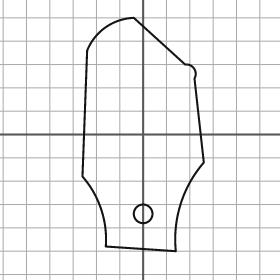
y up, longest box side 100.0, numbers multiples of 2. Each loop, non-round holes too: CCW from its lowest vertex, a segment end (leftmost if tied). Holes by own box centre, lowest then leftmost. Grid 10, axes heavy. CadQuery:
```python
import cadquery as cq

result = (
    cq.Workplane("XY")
    .moveTo(14.0, -50.0)
    .threePointArc((16.0, -30.0), (26.0, -12.0))
    .lineTo(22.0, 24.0)
    .threePointArc((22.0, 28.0), (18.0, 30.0))
    .lineTo(-4.0, 50.0)
    .threePointArc((-16.0, 46.0), (-24.0, 36.0))
    .lineTo(-26.0, -18.0)
    .threePointArc((-18.0, -32.0), (-16.0, -48.0))
    .close()
    .moveTo(0.0, -34.0)
    .circle(4.0)
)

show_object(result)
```